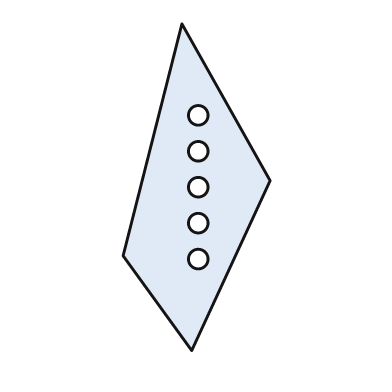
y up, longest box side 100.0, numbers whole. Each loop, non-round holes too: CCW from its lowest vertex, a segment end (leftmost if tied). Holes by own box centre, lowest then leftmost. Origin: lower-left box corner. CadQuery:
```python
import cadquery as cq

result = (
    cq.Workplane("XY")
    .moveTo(21.0, 0.0)
    .lineTo(45.0, 52.0)
    .lineTo(18.0, 100.0)
    .lineTo(0.0, 29.0)
    .close()
    .moveTo(23.0, 28.0)
    .circle(3.0)
    .moveTo(23.0, 39.0)
    .circle(3.0)
    .moveTo(23.0, 50.0)
    .circle(3.0)
    .moveTo(23.0, 61.0)
    .circle(3.0)
    .moveTo(23.0, 72.0)
    .circle(3.0)
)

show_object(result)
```